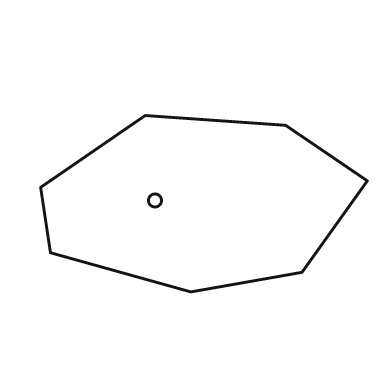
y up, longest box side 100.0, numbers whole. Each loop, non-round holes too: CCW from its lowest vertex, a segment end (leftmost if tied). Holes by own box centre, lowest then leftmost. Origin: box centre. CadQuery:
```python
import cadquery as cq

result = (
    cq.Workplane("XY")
    .moveTo(-4.0, -27.0)
    .lineTo(30.0, -21.0)
    .lineTo(50.0, 7.0)
    .lineTo(25.0, 24.0)
    .lineTo(-18.0, 27.0)
    .lineTo(-50.0, 5.0)
    .lineTo(-47.0, -15.0)
    .close()
    .moveTo(-15.0, 1.0)
    .circle(2.0)
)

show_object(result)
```